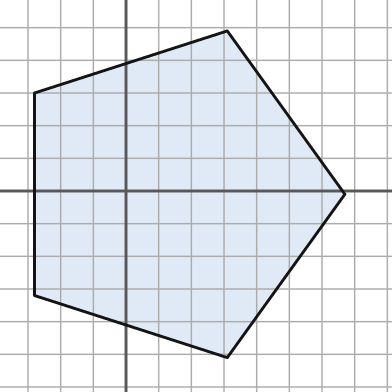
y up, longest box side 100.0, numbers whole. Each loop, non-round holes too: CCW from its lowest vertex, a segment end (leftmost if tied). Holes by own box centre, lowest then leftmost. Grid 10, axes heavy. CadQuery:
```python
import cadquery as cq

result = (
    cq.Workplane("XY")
    .moveTo(31.0, -51.0)
    .lineTo(67.0, -1.0)
    .lineTo(31.0, 49.0)
    .lineTo(-28.0, 30.0)
    .lineTo(-28.0, -32.0)
    .close()
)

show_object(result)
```